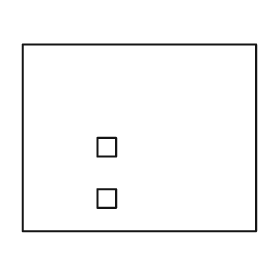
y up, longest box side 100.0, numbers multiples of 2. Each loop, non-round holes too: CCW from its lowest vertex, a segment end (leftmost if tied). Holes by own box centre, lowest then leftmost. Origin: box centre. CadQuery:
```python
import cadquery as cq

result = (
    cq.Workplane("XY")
    .moveTo(-50.0, -40.0)
    .lineTo(50.0, -40.0)
    .lineTo(50.0, 40.0)
    .lineTo(-50.0, 40.0)
    .close()
    .moveTo(-18.0, -30.0)
    .lineTo(-10.0, -30.0)
    .lineTo(-10.0, -22.0)
    .lineTo(-18.0, -22.0)
    .close()
    .moveTo(-18.0, -8.0)
    .lineTo(-10.0, -8.0)
    .lineTo(-10.0, 0.0)
    .lineTo(-18.0, 0.0)
    .close()
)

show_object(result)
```